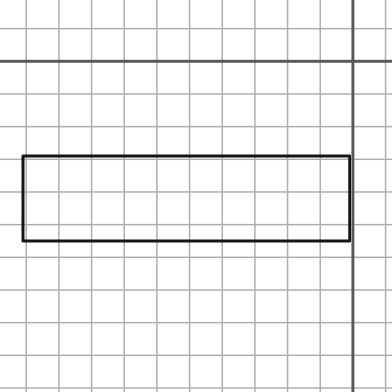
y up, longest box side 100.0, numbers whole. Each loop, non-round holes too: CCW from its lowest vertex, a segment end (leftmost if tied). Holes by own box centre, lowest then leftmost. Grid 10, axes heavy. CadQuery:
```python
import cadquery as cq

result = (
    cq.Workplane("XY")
    .moveTo(-101.0, -55.0)
    .lineTo(-1.0, -55.0)
    .lineTo(-1.0, -29.0)
    .lineTo(-101.0, -29.0)
    .close()
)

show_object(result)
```